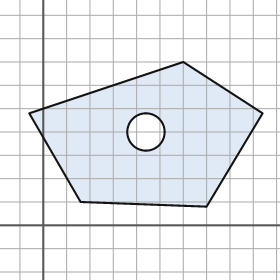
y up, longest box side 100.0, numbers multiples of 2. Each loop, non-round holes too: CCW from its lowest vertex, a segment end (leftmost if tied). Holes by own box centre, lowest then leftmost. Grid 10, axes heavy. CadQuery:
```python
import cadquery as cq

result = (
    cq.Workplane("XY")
    .moveTo(70.0, 8.0)
    .lineTo(94.0, 48.0)
    .lineTo(60.0, 70.0)
    .lineTo(-6.0, 48.0)
    .lineTo(16.0, 10.0)
    .close()
    .moveTo(44.0, 40.0)
    .circle(8.0)
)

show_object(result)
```